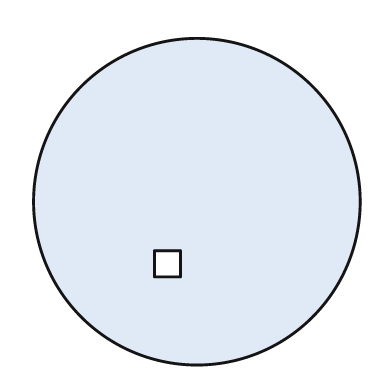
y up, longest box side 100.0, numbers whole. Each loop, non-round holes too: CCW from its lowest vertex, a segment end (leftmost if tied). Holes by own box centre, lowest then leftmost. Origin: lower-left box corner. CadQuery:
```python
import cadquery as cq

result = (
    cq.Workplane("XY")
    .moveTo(50.0, 50.0)
    .circle(50.0)
    .moveTo(37.0, 27.0)
    .lineTo(45.0, 27.0)
    .lineTo(45.0, 35.0)
    .lineTo(37.0, 35.0)
    .close()
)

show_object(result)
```